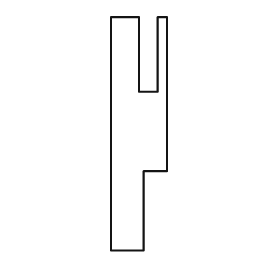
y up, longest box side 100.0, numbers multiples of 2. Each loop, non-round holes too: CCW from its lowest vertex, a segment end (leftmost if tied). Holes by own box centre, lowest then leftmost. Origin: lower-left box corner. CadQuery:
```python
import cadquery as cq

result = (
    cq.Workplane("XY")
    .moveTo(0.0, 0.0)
    .lineTo(14.0, 0.0)
    .lineTo(14.0, 34.0)
    .lineTo(24.0, 34.0)
    .lineTo(24.0, 100.0)
    .lineTo(20.0, 100.0)
    .lineTo(20.0, 68.0)
    .lineTo(12.0, 68.0)
    .lineTo(12.0, 100.0)
    .lineTo(0.0, 100.0)
    .close()
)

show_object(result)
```